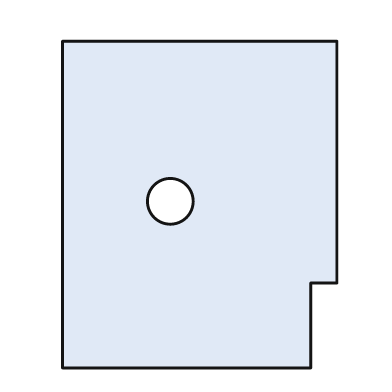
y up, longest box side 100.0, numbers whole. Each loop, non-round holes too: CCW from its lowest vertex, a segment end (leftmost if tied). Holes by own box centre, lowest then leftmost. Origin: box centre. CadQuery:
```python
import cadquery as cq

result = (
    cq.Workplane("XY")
    .moveTo(-42.0, -50.0)
    .lineTo(34.0, -50.0)
    .lineTo(34.0, -24.0)
    .lineTo(42.0, -24.0)
    .lineTo(42.0, 50.0)
    .lineTo(-42.0, 50.0)
    .close()
    .moveTo(-9.0, 1.0)
    .circle(7.0)
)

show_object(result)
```